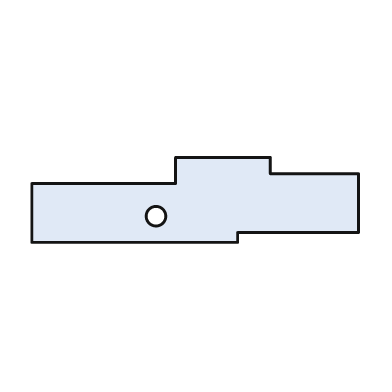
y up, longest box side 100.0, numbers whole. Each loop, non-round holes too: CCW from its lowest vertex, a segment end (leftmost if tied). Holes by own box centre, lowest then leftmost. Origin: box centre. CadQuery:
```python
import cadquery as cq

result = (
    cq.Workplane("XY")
    .moveTo(-50.0, -13.0)
    .lineTo(13.0, -13.0)
    .lineTo(13.0, -10.0)
    .lineTo(50.0, -10.0)
    .lineTo(50.0, 8.0)
    .lineTo(23.0, 8.0)
    .lineTo(23.0, 13.0)
    .lineTo(-6.0, 13.0)
    .lineTo(-6.0, 5.0)
    .lineTo(-50.0, 5.0)
    .close()
    .moveTo(-12.0, -5.0)
    .circle(3.0)
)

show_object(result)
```